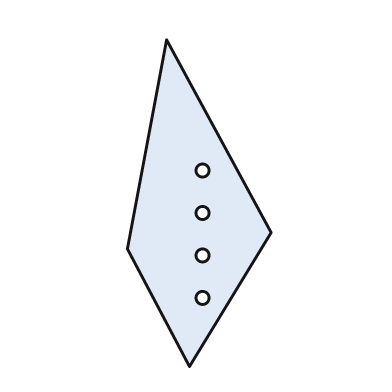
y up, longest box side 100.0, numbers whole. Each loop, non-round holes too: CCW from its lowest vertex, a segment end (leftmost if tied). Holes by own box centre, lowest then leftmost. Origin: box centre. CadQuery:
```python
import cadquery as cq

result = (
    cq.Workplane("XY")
    .moveTo(-3.0, -50.0)
    .lineTo(22.0, -9.0)
    .lineTo(-10.0, 50.0)
    .lineTo(-22.0, -14.0)
    .close()
    .moveTo(1.0, -29.0)
    .circle(2.0)
    .moveTo(1.0, -16.0)
    .circle(2.0)
    .moveTo(1.0, -3.0)
    .circle(2.0)
    .moveTo(1.0, 10.0)
    .circle(2.0)
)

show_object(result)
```